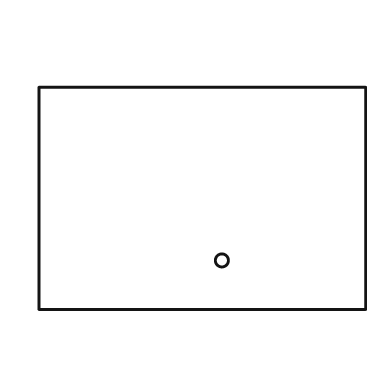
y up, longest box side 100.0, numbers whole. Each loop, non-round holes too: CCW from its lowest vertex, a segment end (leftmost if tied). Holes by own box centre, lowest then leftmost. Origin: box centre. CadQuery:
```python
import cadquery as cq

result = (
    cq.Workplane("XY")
    .moveTo(-50.0, -34.0)
    .lineTo(50.0, -34.0)
    .lineTo(50.0, 34.0)
    .lineTo(-50.0, 34.0)
    .close()
    .moveTo(6.0, -19.0)
    .circle(2.0)
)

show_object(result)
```